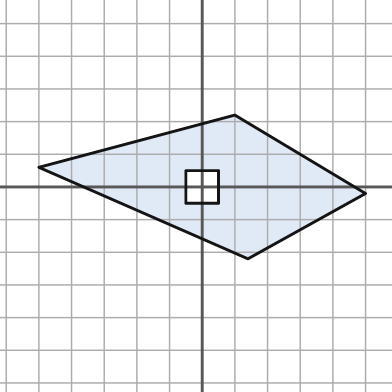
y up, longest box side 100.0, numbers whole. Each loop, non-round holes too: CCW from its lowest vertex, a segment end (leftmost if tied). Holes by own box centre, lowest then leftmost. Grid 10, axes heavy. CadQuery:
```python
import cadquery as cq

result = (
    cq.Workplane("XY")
    .moveTo(14.0, -22.0)
    .lineTo(50.0, -2.0)
    .lineTo(10.0, 22.0)
    .lineTo(-50.0, 6.0)
    .close()
    .moveTo(-5.0, -5.0)
    .lineTo(5.0, -5.0)
    .lineTo(5.0, 5.0)
    .lineTo(-5.0, 5.0)
    .close()
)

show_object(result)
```